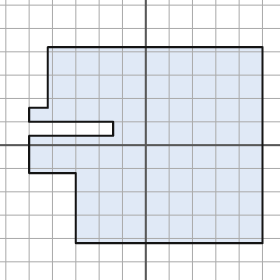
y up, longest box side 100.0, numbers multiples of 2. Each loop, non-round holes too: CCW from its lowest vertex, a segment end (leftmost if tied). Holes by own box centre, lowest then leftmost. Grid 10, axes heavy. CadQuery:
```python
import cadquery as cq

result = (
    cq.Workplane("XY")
    .moveTo(-30.0, -42.0)
    .lineTo(50.0, -42.0)
    .lineTo(50.0, 42.0)
    .lineTo(-42.0, 42.0)
    .lineTo(-42.0, 16.0)
    .lineTo(-50.0, 16.0)
    .lineTo(-50.0, 10.0)
    .lineTo(-14.0, 10.0)
    .lineTo(-14.0, 4.0)
    .lineTo(-50.0, 4.0)
    .lineTo(-50.0, -12.0)
    .lineTo(-30.0, -12.0)
    .close()
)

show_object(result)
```